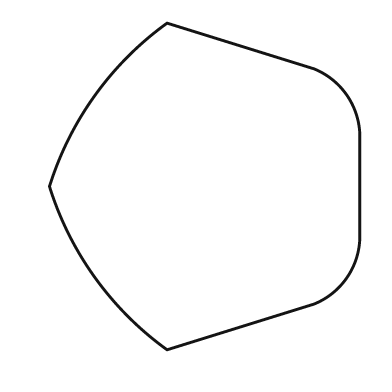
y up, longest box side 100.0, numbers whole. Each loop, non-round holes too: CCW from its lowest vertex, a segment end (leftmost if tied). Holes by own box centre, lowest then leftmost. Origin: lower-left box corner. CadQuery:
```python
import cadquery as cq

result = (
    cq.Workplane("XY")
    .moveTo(36.0, 0.0)
    .lineTo(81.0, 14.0)
    .threePointArc((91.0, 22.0), (95.0, 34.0))
    .lineTo(95.0, 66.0)
    .threePointArc((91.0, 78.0), (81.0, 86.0))
    .lineTo(36.0, 100.0)
    .threePointArc((14.0, 78.0), (0.0, 50.0))
    .threePointArc((14.0, 22.0), (36.0, 0.0))
    .close()
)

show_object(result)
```